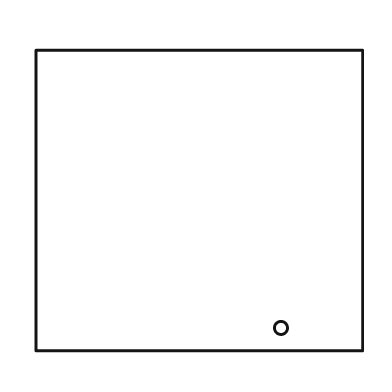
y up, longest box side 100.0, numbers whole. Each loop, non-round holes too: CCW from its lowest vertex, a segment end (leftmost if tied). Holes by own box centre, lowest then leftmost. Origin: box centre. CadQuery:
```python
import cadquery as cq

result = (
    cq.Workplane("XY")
    .moveTo(-50.0, -46.0)
    .lineTo(50.0, -46.0)
    .lineTo(50.0, 46.0)
    .lineTo(-50.0, 46.0)
    .close()
    .moveTo(25.0, -39.0)
    .circle(2.0)
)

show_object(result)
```